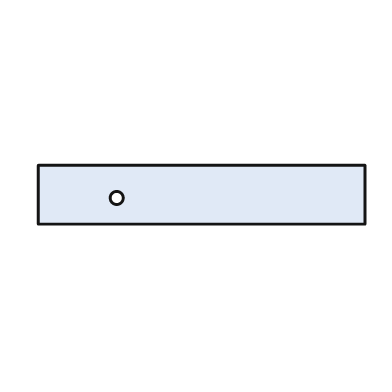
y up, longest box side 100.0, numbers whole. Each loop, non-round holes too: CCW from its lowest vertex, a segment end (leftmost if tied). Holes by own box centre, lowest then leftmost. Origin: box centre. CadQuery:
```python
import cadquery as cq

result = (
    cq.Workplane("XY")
    .moveTo(-50.0, -9.0)
    .lineTo(50.0, -9.0)
    .lineTo(50.0, 9.0)
    .lineTo(-50.0, 9.0)
    .close()
    .moveTo(-26.0, -1.0)
    .circle(2.0)
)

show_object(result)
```